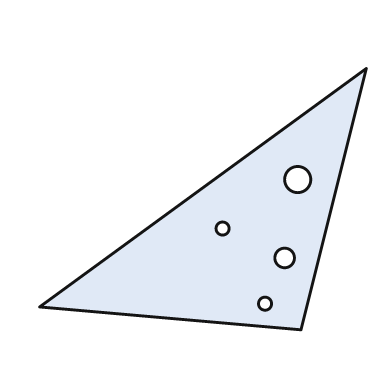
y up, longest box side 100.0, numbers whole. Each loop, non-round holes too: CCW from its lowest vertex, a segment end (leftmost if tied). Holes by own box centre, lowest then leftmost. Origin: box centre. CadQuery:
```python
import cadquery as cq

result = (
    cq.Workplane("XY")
    .moveTo(30.0, -40.0)
    .lineTo(50.0, 40.0)
    .lineTo(-50.0, -33.0)
    .close()
    .moveTo(19.0, -32.0)
    .circle(2.0)
    .moveTo(25.0, -18.0)
    .circle(3.0)
    .moveTo(6.0, -9.0)
    .circle(2.0)
    .moveTo(29.0, 6.0)
    .circle(4.0)
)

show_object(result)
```